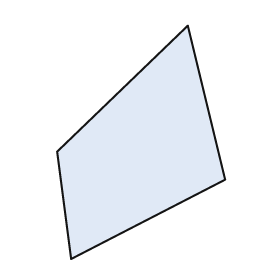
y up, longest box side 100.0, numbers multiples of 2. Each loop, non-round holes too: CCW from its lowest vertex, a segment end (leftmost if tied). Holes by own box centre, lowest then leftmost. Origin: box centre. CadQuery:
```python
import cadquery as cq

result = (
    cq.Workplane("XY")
    .moveTo(-30.0, -50.0)
    .lineTo(36.0, -16.0)
    .lineTo(20.0, 50.0)
    .lineTo(-36.0, -4.0)
    .close()
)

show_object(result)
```